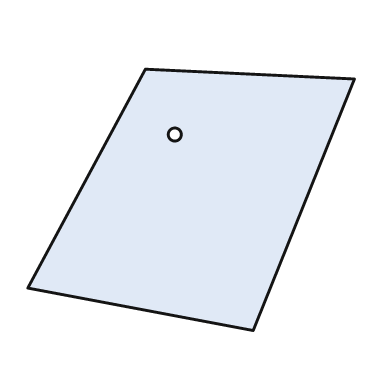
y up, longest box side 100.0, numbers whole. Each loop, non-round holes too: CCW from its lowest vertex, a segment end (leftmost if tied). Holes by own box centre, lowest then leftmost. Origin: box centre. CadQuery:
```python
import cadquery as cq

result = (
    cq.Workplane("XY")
    .moveTo(19.0, -40.0)
    .lineTo(50.0, 37.0)
    .lineTo(-14.0, 40.0)
    .lineTo(-50.0, -27.0)
    .close()
    .moveTo(-5.0, 20.0)
    .circle(2.0)
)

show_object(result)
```